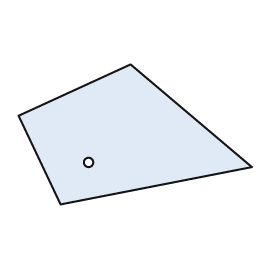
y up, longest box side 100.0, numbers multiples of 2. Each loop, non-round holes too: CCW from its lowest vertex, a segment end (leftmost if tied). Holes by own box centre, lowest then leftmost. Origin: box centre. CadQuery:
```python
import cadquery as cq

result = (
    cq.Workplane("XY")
    .moveTo(-32.0, -30.0)
    .lineTo(50.0, -14.0)
    .lineTo(-2.0, 30.0)
    .lineTo(-50.0, 8.0)
    .close()
    .moveTo(-20.0, -12.0)
    .circle(2.0)
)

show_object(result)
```